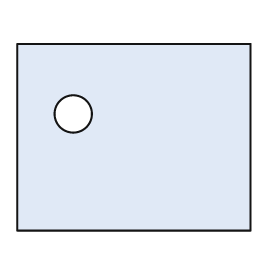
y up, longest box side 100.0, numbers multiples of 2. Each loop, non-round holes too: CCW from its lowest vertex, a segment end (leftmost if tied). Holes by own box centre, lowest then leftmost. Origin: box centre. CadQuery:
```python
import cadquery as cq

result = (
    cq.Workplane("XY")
    .moveTo(-50.0, -40.0)
    .lineTo(50.0, -40.0)
    .lineTo(50.0, 40.0)
    .lineTo(-50.0, 40.0)
    .close()
    .moveTo(-26.0, 10.0)
    .circle(8.0)
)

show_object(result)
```